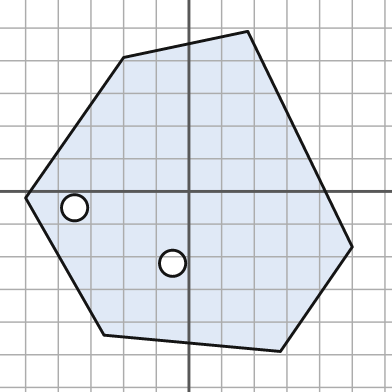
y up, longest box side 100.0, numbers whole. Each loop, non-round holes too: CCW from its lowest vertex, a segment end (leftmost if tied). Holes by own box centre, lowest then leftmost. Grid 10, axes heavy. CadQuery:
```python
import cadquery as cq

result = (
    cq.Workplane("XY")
    .moveTo(28.0, -49.0)
    .lineTo(50.0, -17.0)
    .lineTo(18.0, 49.0)
    .lineTo(-20.0, 41.0)
    .lineTo(-50.0, -2.0)
    .lineTo(-26.0, -44.0)
    .close()
    .moveTo(-5.0, -22.0)
    .circle(4.0)
    .moveTo(-35.0, -5.0)
    .circle(4.0)
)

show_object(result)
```